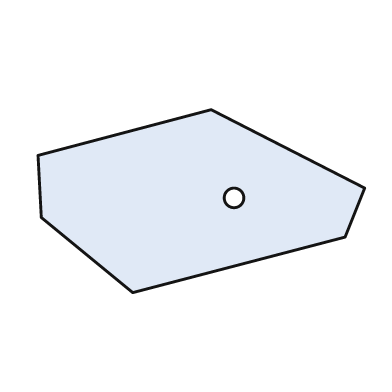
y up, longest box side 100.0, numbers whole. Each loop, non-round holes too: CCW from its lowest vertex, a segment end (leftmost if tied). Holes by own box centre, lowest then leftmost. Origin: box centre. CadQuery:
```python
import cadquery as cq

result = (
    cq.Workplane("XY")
    .moveTo(-21.0, -28.0)
    .lineTo(44.0, -11.0)
    .lineTo(50.0, 4.0)
    .lineTo(3.0, 28.0)
    .lineTo(-50.0, 14.0)
    .lineTo(-49.0, -5.0)
    .close()
    .moveTo(10.0, 1.0)
    .circle(3.0)
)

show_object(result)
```